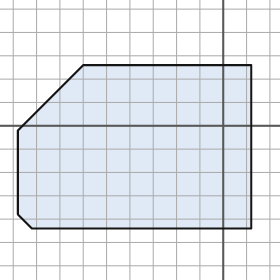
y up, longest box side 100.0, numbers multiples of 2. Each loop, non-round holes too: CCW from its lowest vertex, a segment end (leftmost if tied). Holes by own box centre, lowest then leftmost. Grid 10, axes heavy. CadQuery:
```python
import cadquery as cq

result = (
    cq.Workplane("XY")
    .moveTo(-82.0, -44.0)
    .lineTo(12.0, -44.0)
    .lineTo(12.0, 26.0)
    .lineTo(-60.0, 26.0)
    .lineTo(-88.0, -2.0)
    .lineTo(-88.0, -38.0)
    .close()
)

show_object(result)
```